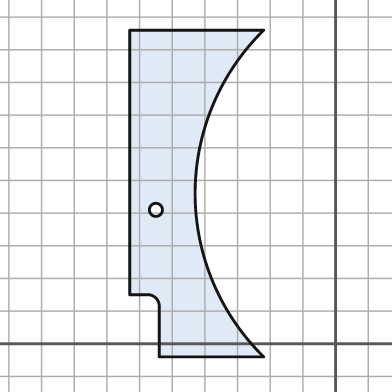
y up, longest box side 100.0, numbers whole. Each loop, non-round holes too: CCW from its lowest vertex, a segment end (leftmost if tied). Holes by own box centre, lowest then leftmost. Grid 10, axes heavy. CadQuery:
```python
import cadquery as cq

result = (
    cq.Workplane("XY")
    .moveTo(-54.0, -4.0)
    .lineTo(-22.0, -4.0)
    .threePointArc((-43.0, 46.0), (-22.0, 96.0))
    .lineTo(-63.0, 96.0)
    .lineTo(-63.0, 15.0)
    .lineTo(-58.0, 15.0)
    .threePointArc((-55.0, 14.0), (-54.0, 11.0))
    .close()
    .moveTo(-55.0, 41.0)
    .circle(2.0)
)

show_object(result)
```